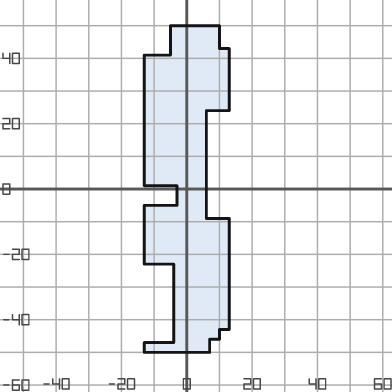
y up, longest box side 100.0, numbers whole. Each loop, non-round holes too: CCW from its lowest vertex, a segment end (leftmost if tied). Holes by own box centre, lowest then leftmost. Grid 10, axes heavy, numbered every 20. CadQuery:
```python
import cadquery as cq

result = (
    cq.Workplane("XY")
    .moveTo(-13.0, -50.0)
    .lineTo(7.0, -50.0)
    .lineTo(7.0, -46.0)
    .lineTo(10.0, -46.0)
    .lineTo(10.0, -43.0)
    .lineTo(13.0, -43.0)
    .lineTo(13.0, -9.0)
    .lineTo(6.0, -9.0)
    .lineTo(6.0, 24.0)
    .lineTo(13.0, 24.0)
    .lineTo(13.0, 43.0)
    .lineTo(10.0, 43.0)
    .lineTo(10.0, 50.0)
    .lineTo(-5.0, 50.0)
    .lineTo(-5.0, 41.0)
    .lineTo(-13.0, 41.0)
    .lineTo(-13.0, 1.0)
    .lineTo(-3.0, 1.0)
    .lineTo(-3.0, -5.0)
    .lineTo(-13.0, -5.0)
    .lineTo(-13.0, -23.0)
    .lineTo(-4.0, -23.0)
    .lineTo(-4.0, -47.0)
    .lineTo(-13.0, -47.0)
    .close()
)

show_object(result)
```